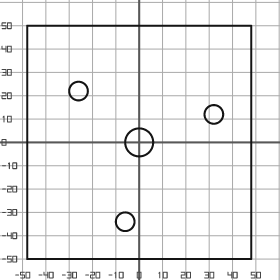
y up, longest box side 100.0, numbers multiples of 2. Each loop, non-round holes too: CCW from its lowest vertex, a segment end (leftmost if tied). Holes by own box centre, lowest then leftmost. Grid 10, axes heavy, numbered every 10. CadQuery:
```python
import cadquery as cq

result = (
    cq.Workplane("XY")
    .moveTo(-48.0, -50.0)
    .lineTo(48.0, -50.0)
    .lineTo(48.0, 50.0)
    .lineTo(-48.0, 50.0)
    .close()
    .moveTo(-6.0, -34.0)
    .circle(4.0)
    .moveTo(0.0, 0.0)
    .circle(6.0)
    .moveTo(32.0, 12.0)
    .circle(4.0)
    .moveTo(-26.0, 22.0)
    .circle(4.0)
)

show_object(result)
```